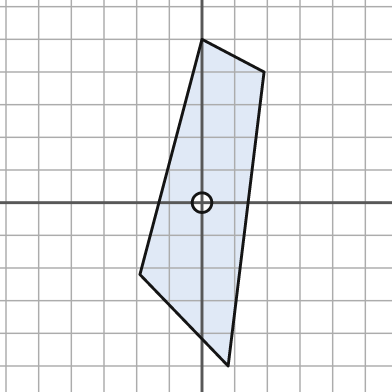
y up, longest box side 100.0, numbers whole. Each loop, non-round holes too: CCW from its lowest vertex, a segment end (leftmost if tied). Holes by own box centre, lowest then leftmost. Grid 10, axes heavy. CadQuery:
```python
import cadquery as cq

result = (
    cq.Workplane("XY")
    .moveTo(8.0, -50.0)
    .lineTo(19.0, 40.0)
    .lineTo(0.0, 50.0)
    .lineTo(-19.0, -22.0)
    .close()
    .moveTo(0.0, 0.0)
    .circle(3.0)
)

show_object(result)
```